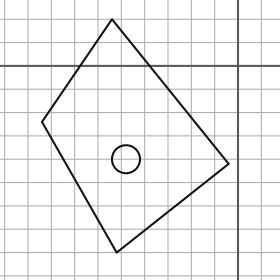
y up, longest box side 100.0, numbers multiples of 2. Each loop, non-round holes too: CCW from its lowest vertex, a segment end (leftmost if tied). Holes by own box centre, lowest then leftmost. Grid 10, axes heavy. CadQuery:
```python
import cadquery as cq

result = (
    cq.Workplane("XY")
    .moveTo(-52.0, -80.0)
    .lineTo(-4.0, -42.0)
    .lineTo(-54.0, 20.0)
    .lineTo(-84.0, -24.0)
    .close()
    .moveTo(-48.0, -40.0)
    .circle(6.0)
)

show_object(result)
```